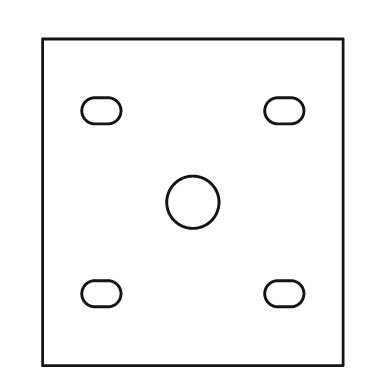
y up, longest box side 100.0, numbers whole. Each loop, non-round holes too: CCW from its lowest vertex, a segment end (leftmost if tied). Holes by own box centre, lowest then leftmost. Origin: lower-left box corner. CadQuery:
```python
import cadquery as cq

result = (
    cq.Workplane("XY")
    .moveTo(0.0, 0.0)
    .lineTo(92.0, 0.0)
    .lineTo(92.0, 100.0)
    .lineTo(0.0, 100.0)
    .close()
    .moveTo(16.0, 18.0)
    .lineTo(20.0, 18.0)
    .threePointArc((24.0, 22.0), (20.0, 26.0))
    .lineTo(16.0, 26.0)
    .threePointArc((12.0, 22.0), (16.0, 18.0))
    .close()
    .moveTo(72.0, 18.0)
    .lineTo(76.0, 18.0)
    .threePointArc((80.0, 22.0), (76.0, 26.0))
    .lineTo(72.0, 26.0)
    .threePointArc((68.0, 22.0), (72.0, 18.0))
    .close()
    .moveTo(46.0, 50.0)
    .circle(8.0)
    .moveTo(16.0, 74.0)
    .lineTo(20.0, 74.0)
    .threePointArc((24.0, 78.0), (20.0, 82.0))
    .lineTo(16.0, 82.0)
    .threePointArc((12.0, 78.0), (16.0, 74.0))
    .close()
    .moveTo(72.0, 74.0)
    .lineTo(76.0, 74.0)
    .threePointArc((80.0, 78.0), (76.0, 82.0))
    .lineTo(72.0, 82.0)
    .threePointArc((68.0, 78.0), (72.0, 74.0))
    .close()
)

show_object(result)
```